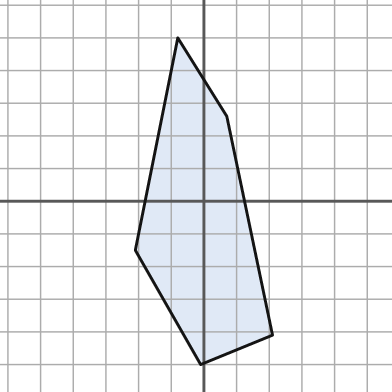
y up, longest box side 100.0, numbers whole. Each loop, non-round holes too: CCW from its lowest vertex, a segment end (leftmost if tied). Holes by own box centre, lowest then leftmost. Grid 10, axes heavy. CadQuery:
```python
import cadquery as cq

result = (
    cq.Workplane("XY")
    .moveTo(-1.0, -50.0)
    .lineTo(21.0, -41.0)
    .lineTo(7.0, 26.0)
    .lineTo(-8.0, 50.0)
    .lineTo(-21.0, -15.0)
    .close()
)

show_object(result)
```